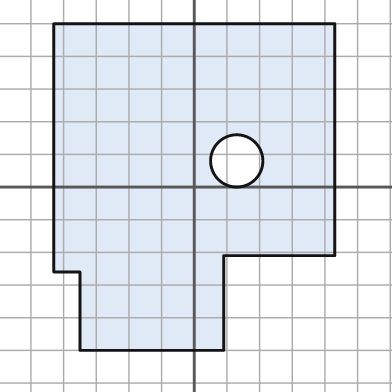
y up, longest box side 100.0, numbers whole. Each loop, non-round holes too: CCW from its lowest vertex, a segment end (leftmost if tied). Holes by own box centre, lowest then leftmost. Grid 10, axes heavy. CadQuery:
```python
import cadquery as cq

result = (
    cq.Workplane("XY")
    .moveTo(-35.0, -50.0)
    .lineTo(9.0, -50.0)
    .lineTo(9.0, -21.0)
    .lineTo(43.0, -21.0)
    .lineTo(43.0, 50.0)
    .lineTo(-43.0, 50.0)
    .lineTo(-43.0, -26.0)
    .lineTo(-35.0, -26.0)
    .close()
    .moveTo(13.0, 8.0)
    .circle(8.0)
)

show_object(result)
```